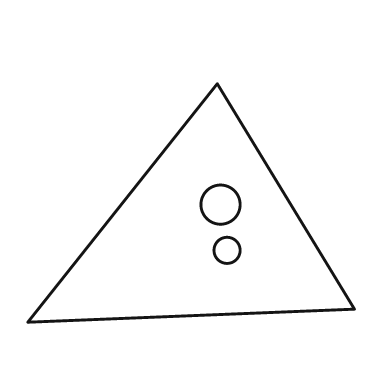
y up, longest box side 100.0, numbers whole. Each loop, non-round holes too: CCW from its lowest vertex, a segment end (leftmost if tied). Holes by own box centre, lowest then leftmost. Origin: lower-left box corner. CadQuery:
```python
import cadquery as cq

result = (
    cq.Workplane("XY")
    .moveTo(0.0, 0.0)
    .lineTo(100.0, 4.0)
    .lineTo(58.0, 73.0)
    .close()
    .moveTo(61.0, 22.0)
    .circle(4.0)
    .moveTo(59.0, 36.0)
    .circle(6.0)
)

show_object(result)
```